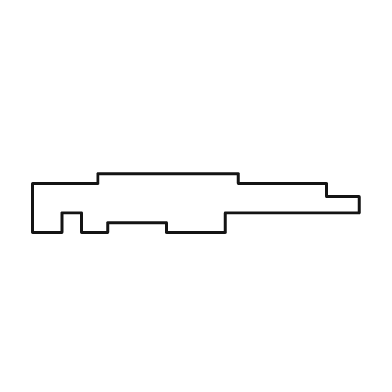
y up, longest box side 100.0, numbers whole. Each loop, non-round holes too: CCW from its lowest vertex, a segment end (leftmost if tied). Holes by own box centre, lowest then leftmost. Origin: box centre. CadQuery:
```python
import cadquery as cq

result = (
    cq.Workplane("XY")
    .moveTo(-50.0, -9.0)
    .lineTo(-41.0, -9.0)
    .lineTo(-41.0, -3.0)
    .lineTo(-35.0, -3.0)
    .lineTo(-35.0, -9.0)
    .lineTo(-27.0, -9.0)
    .lineTo(-27.0, -6.0)
    .lineTo(-9.0, -6.0)
    .lineTo(-9.0, -9.0)
    .lineTo(9.0, -9.0)
    .lineTo(9.0, -3.0)
    .lineTo(50.0, -3.0)
    .lineTo(50.0, 2.0)
    .lineTo(40.0, 2.0)
    .lineTo(40.0, 6.0)
    .lineTo(13.0, 6.0)
    .lineTo(13.0, 9.0)
    .lineTo(-30.0, 9.0)
    .lineTo(-30.0, 6.0)
    .lineTo(-50.0, 6.0)
    .close()
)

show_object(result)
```